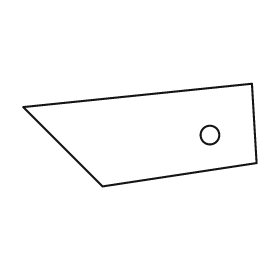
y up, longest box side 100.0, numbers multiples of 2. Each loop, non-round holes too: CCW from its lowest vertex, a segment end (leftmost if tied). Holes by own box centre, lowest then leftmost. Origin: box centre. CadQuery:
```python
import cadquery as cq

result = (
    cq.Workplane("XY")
    .moveTo(-16.0, -22.0)
    .lineTo(50.0, -12.0)
    .lineTo(48.0, 22.0)
    .lineTo(-50.0, 12.0)
    .close()
    .moveTo(30.0, 0.0)
    .circle(4.0)
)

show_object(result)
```